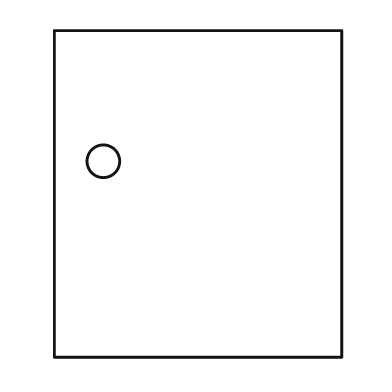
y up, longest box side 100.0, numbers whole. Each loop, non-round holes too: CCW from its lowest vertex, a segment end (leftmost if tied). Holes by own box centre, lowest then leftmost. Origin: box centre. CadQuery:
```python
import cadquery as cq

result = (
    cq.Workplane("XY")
    .moveTo(-44.0, -50.0)
    .lineTo(44.0, -50.0)
    .lineTo(44.0, 50.0)
    .lineTo(-44.0, 50.0)
    .close()
    .moveTo(-29.0, 10.0)
    .circle(5.0)
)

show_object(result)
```